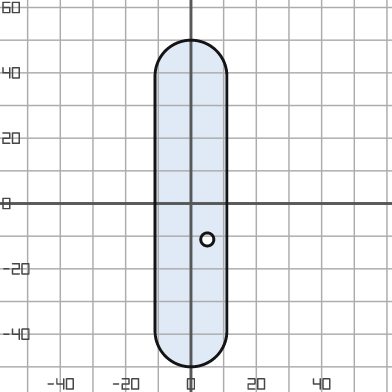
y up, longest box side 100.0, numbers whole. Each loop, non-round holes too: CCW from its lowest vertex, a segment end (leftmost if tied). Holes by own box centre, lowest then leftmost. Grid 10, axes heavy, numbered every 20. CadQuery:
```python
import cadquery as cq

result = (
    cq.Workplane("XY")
    .moveTo(-11.0, -39.0)
    .threePointArc((0.0, -50.0), (11.0, -39.0))
    .lineTo(11.0, 39.0)
    .threePointArc((0.0, 50.0), (-11.0, 39.0))
    .close()
    .moveTo(5.0, -11.0)
    .circle(2.0)
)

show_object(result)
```